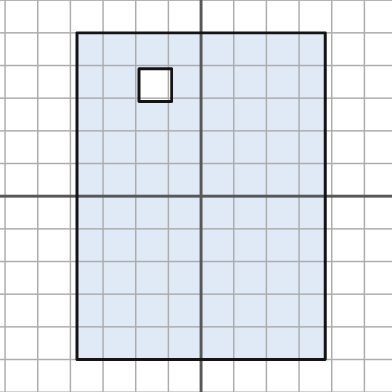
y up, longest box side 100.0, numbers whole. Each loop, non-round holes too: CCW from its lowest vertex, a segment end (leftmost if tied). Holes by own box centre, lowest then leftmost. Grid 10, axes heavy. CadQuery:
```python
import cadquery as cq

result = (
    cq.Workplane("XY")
    .moveTo(-38.0, -50.0)
    .lineTo(38.0, -50.0)
    .lineTo(38.0, 50.0)
    .lineTo(-38.0, 50.0)
    .close()
    .moveTo(-19.0, 29.0)
    .lineTo(-9.0, 29.0)
    .lineTo(-9.0, 39.0)
    .lineTo(-19.0, 39.0)
    .close()
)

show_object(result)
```